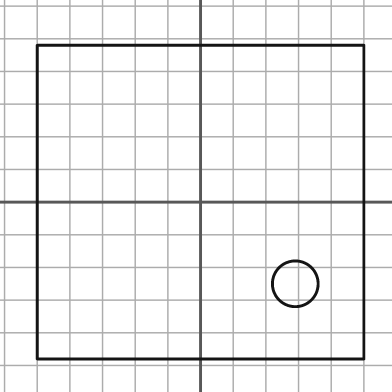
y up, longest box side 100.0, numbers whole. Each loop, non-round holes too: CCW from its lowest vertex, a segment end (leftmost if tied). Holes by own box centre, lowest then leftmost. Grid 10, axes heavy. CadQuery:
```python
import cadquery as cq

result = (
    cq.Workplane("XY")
    .moveTo(-50.0, -48.0)
    .lineTo(50.0, -48.0)
    .lineTo(50.0, 48.0)
    .lineTo(-50.0, 48.0)
    .close()
    .moveTo(29.0, -25.0)
    .circle(7.0)
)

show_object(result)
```